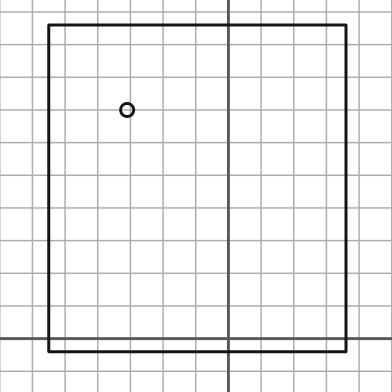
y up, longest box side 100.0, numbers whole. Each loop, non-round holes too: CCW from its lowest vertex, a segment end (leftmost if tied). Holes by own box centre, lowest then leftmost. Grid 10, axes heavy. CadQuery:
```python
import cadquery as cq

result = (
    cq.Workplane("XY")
    .moveTo(-55.0, -4.0)
    .lineTo(36.0, -4.0)
    .lineTo(36.0, 96.0)
    .lineTo(-55.0, 96.0)
    .close()
    .moveTo(-31.0, 70.0)
    .circle(2.0)
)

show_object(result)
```